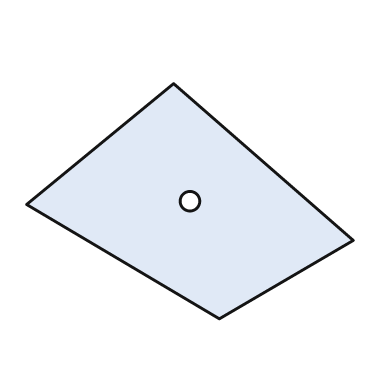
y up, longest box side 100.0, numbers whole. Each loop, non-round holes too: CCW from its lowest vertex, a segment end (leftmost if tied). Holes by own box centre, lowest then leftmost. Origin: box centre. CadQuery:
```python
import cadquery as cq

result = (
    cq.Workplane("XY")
    .moveTo(9.0, -36.0)
    .lineTo(50.0, -12.0)
    .lineTo(-5.0, 36.0)
    .lineTo(-50.0, -1.0)
    .close()
    .moveTo(0.0, 0.0)
    .circle(3.0)
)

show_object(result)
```